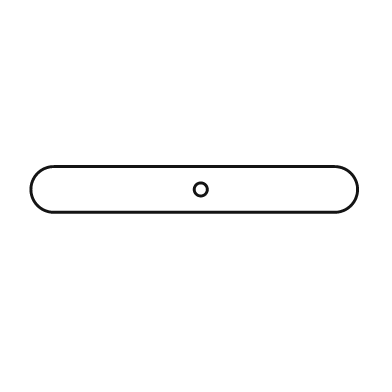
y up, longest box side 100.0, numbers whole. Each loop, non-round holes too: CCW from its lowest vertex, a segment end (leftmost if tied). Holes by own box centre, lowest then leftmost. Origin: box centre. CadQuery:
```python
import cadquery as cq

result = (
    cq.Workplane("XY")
    .moveTo(-43.0, -7.0)
    .lineTo(43.0, -7.0)
    .threePointArc((50.0, 0.0), (43.0, 7.0))
    .lineTo(-43.0, 7.0)
    .threePointArc((-50.0, 0.0), (-43.0, -7.0))
    .close()
    .moveTo(2.0, 0.0)
    .circle(2.0)
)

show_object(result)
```